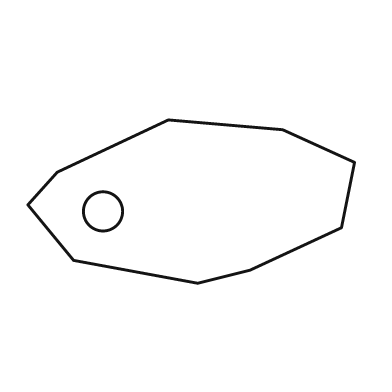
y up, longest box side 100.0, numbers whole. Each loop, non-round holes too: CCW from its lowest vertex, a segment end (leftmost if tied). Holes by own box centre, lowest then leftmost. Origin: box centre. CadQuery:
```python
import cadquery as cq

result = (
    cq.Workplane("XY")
    .moveTo(2.0, -25.0)
    .lineTo(18.0, -21.0)
    .lineTo(46.0, -8.0)
    .lineTo(50.0, 12.0)
    .lineTo(28.0, 22.0)
    .lineTo(-7.0, 25.0)
    .lineTo(-41.0, 9.0)
    .lineTo(-50.0, -1.0)
    .lineTo(-36.0, -18.0)
    .close()
    .moveTo(-27.0, -3.0)
    .circle(6.0)
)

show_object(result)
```